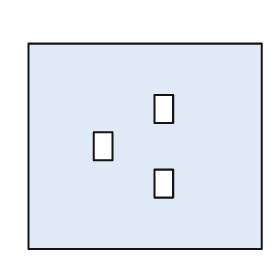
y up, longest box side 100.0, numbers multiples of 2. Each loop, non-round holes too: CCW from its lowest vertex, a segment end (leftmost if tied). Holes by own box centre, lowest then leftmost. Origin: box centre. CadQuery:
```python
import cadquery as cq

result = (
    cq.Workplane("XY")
    .moveTo(-50.0, -44.0)
    .lineTo(50.0, -44.0)
    .lineTo(50.0, 44.0)
    .lineTo(-50.0, 44.0)
    .close()
    .moveTo(4.0, -22.0)
    .lineTo(12.0, -22.0)
    .lineTo(12.0, -10.0)
    .lineTo(4.0, -10.0)
    .close()
    .moveTo(-22.0, -6.0)
    .lineTo(-14.0, -6.0)
    .lineTo(-14.0, 6.0)
    .lineTo(-22.0, 6.0)
    .close()
    .moveTo(4.0, 10.0)
    .lineTo(12.0, 10.0)
    .lineTo(12.0, 22.0)
    .lineTo(4.0, 22.0)
    .close()
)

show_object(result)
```